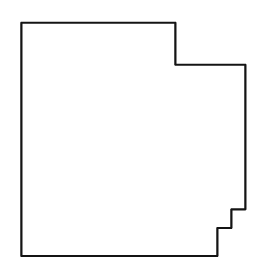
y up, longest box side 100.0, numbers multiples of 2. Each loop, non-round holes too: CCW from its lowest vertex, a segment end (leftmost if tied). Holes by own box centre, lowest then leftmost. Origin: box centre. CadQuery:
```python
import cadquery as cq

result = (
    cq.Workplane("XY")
    .moveTo(-48.0, -50.0)
    .lineTo(36.0, -50.0)
    .lineTo(36.0, -38.0)
    .lineTo(42.0, -38.0)
    .lineTo(42.0, -30.0)
    .lineTo(48.0, -30.0)
    .lineTo(48.0, 32.0)
    .lineTo(18.0, 32.0)
    .lineTo(18.0, 50.0)
    .lineTo(-48.0, 50.0)
    .close()
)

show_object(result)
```